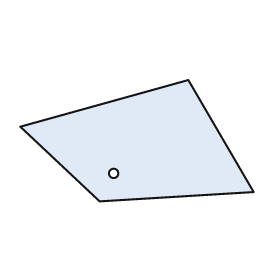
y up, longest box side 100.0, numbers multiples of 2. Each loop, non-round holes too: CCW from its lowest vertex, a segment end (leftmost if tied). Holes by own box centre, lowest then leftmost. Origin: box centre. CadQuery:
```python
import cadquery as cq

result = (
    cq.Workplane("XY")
    .moveTo(-16.0, -26.0)
    .lineTo(50.0, -22.0)
    .lineTo(22.0, 26.0)
    .lineTo(-50.0, 6.0)
    .close()
    .moveTo(-10.0, -14.0)
    .circle(2.0)
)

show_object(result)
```